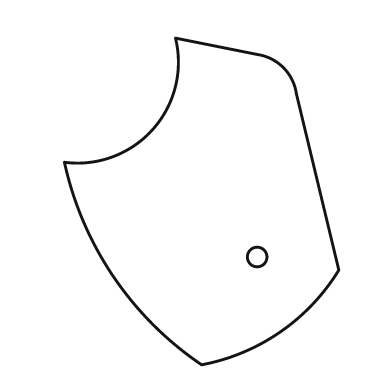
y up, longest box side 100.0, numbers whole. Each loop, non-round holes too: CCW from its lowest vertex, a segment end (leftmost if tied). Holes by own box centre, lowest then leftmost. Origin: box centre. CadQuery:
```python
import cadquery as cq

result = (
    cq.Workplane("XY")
    .moveTo(0.0, -50.0)
    .threePointArc((24.0, -40.0), (42.0, -21.0))
    .lineTo(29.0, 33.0)
    .threePointArc((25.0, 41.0), (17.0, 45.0))
    .lineTo(-8.0, 50.0)
    .threePointArc((-15.0, 22.0), (-42.0, 12.0))
    .threePointArc((-27.0, -23.0), (0.0, -50.0))
    .close()
    .moveTo(17.0, -17.0)
    .circle(3.0)
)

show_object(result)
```